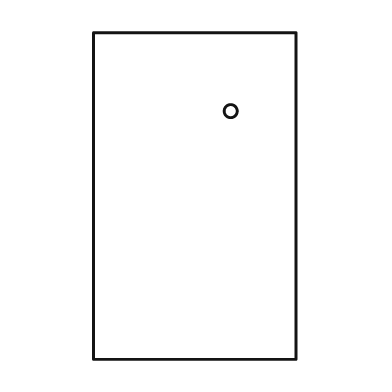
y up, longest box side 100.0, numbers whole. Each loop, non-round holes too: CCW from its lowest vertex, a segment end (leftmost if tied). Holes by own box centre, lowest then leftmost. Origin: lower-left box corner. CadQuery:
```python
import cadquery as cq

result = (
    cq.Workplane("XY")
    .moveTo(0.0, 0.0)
    .lineTo(62.0, 0.0)
    .lineTo(62.0, 100.0)
    .lineTo(0.0, 100.0)
    .close()
    .moveTo(42.0, 76.0)
    .circle(2.0)
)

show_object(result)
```